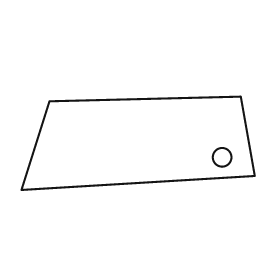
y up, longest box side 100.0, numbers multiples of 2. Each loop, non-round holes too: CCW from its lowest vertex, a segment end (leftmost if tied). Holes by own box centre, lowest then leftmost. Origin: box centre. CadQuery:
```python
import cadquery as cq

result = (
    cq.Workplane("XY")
    .moveTo(-50.0, -20.0)
    .lineTo(50.0, -14.0)
    .lineTo(44.0, 20.0)
    .lineTo(-38.0, 18.0)
    .close()
    .moveTo(36.0, -6.0)
    .circle(4.0)
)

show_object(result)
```